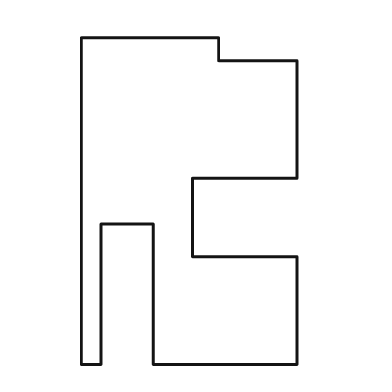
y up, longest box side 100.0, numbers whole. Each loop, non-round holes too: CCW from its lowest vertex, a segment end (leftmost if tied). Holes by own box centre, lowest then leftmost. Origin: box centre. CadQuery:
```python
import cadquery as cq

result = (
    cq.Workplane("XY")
    .moveTo(-33.0, -50.0)
    .lineTo(-27.0, -50.0)
    .lineTo(-27.0, -7.0)
    .lineTo(-11.0, -7.0)
    .lineTo(-11.0, -50.0)
    .lineTo(33.0, -50.0)
    .lineTo(33.0, -17.0)
    .lineTo(1.0, -17.0)
    .lineTo(1.0, 7.0)
    .lineTo(33.0, 7.0)
    .lineTo(33.0, 43.0)
    .lineTo(9.0, 43.0)
    .lineTo(9.0, 50.0)
    .lineTo(-33.0, 50.0)
    .close()
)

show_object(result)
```